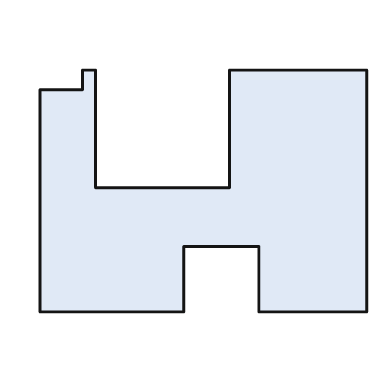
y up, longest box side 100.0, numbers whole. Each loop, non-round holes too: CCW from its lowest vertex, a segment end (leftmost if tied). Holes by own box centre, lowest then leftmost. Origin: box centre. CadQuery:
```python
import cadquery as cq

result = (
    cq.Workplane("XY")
    .moveTo(-50.0, -37.0)
    .lineTo(-6.0, -37.0)
    .lineTo(-6.0, -17.0)
    .lineTo(17.0, -17.0)
    .lineTo(17.0, -37.0)
    .lineTo(50.0, -37.0)
    .lineTo(50.0, 37.0)
    .lineTo(8.0, 37.0)
    .lineTo(8.0, 1.0)
    .lineTo(-33.0, 1.0)
    .lineTo(-33.0, 37.0)
    .lineTo(-37.0, 37.0)
    .lineTo(-37.0, 31.0)
    .lineTo(-50.0, 31.0)
    .close()
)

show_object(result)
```